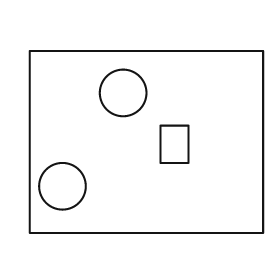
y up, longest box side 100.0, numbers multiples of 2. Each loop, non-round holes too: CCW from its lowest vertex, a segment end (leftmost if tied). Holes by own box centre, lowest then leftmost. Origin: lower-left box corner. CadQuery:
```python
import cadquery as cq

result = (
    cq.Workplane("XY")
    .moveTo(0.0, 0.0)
    .lineTo(100.0, 0.0)
    .lineTo(100.0, 78.0)
    .lineTo(0.0, 78.0)
    .close()
    .moveTo(14.0, 20.0)
    .circle(10.0)
    .moveTo(56.0, 30.0)
    .lineTo(68.0, 30.0)
    .lineTo(68.0, 46.0)
    .lineTo(56.0, 46.0)
    .close()
    .moveTo(40.0, 60.0)
    .circle(10.0)
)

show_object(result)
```